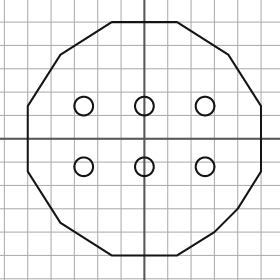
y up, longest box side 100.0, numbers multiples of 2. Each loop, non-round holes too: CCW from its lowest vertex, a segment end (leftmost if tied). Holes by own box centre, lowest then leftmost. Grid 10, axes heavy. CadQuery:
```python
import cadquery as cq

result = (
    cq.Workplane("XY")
    .moveTo(-14.0, -50.0)
    .lineTo(14.0, -50.0)
    .lineTo(30.0, -40.0)
    .lineTo(40.0, -30.0)
    .lineTo(50.0, -14.0)
    .lineTo(50.0, 14.0)
    .lineTo(36.0, 36.0)
    .lineTo(14.0, 50.0)
    .lineTo(-14.0, 50.0)
    .lineTo(-36.0, 36.0)
    .lineTo(-50.0, 14.0)
    .lineTo(-50.0, -14.0)
    .lineTo(-36.0, -36.0)
    .close()
    .moveTo(-26.0, -12.0)
    .circle(4.0)
    .moveTo(0.0, -12.0)
    .circle(4.0)
    .moveTo(26.0, -12.0)
    .circle(4.0)
    .moveTo(-26.0, 14.0)
    .circle(4.0)
    .moveTo(0.0, 14.0)
    .circle(4.0)
    .moveTo(26.0, 14.0)
    .circle(4.0)
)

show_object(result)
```